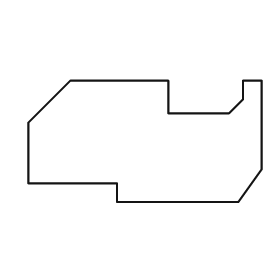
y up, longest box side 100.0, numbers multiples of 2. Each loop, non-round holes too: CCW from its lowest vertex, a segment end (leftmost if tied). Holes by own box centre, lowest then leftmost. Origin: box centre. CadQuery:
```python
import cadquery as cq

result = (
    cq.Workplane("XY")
    .moveTo(-12.0, -26.0)
    .lineTo(40.0, -26.0)
    .lineTo(50.0, -12.0)
    .lineTo(50.0, 26.0)
    .lineTo(42.0, 26.0)
    .lineTo(42.0, 18.0)
    .lineTo(36.0, 12.0)
    .lineTo(10.0, 12.0)
    .lineTo(10.0, 26.0)
    .lineTo(-32.0, 26.0)
    .lineTo(-50.0, 8.0)
    .lineTo(-50.0, -18.0)
    .lineTo(-12.0, -18.0)
    .close()
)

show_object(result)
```